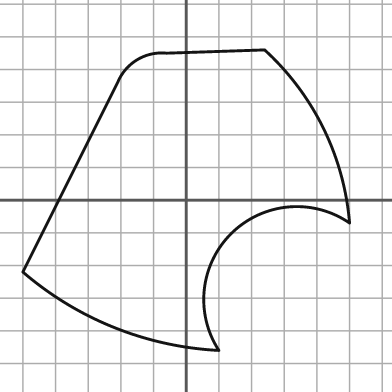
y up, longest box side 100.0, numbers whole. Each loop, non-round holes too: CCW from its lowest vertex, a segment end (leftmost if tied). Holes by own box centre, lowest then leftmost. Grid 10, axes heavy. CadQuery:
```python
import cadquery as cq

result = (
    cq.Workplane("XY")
    .moveTo(10.0, -46.0)
    .threePointArc((14.0, -10.0), (50.0, -7.0))
    .threePointArc((42.0, 22.0), (24.0, 46.0))
    .lineTo(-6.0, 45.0)
    .threePointArc((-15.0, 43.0), (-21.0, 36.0))
    .lineTo(-50.0, -22.0)
    .threePointArc((-22.0, -39.0), (10.0, -46.0))
    .close()
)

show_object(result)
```